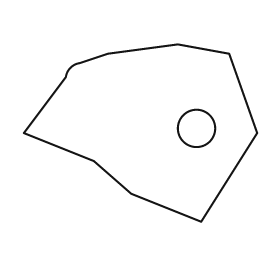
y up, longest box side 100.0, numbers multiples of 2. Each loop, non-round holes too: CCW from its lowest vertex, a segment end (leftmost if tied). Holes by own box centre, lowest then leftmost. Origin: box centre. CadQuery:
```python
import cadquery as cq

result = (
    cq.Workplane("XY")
    .moveTo(26.0, -38.0)
    .lineTo(50.0, 0.0)
    .lineTo(38.0, 34.0)
    .lineTo(16.0, 38.0)
    .lineTo(-14.0, 34.0)
    .lineTo(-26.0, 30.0)
    .threePointArc((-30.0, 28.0), (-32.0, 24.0))
    .lineTo(-50.0, 0.0)
    .lineTo(-20.0, -12.0)
    .lineTo(-4.0, -26.0)
    .close()
    .moveTo(24.0, 2.0)
    .circle(8.0)
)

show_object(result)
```